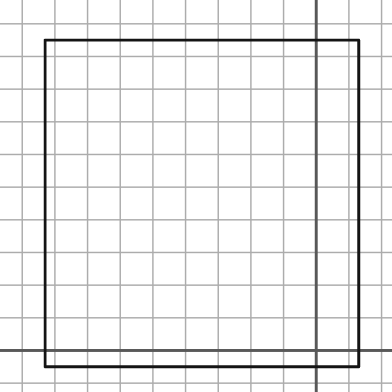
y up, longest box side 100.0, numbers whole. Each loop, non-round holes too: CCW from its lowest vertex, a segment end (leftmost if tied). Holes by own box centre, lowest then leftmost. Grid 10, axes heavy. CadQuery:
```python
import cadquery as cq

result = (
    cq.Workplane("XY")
    .moveTo(-83.0, -5.0)
    .lineTo(13.0, -5.0)
    .lineTo(13.0, 95.0)
    .lineTo(-83.0, 95.0)
    .close()
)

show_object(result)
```